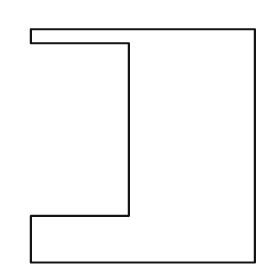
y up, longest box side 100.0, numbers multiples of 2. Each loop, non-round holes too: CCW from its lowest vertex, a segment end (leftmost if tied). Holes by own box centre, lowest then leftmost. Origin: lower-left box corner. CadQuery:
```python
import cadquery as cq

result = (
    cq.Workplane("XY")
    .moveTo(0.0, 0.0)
    .lineTo(96.0, 0.0)
    .lineTo(96.0, 100.0)
    .lineTo(0.0, 100.0)
    .lineTo(0.0, 94.0)
    .lineTo(42.0, 94.0)
    .lineTo(42.0, 20.0)
    .lineTo(0.0, 20.0)
    .close()
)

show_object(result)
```